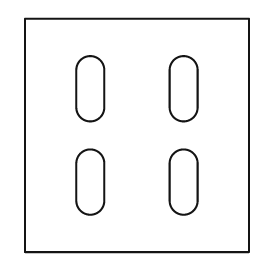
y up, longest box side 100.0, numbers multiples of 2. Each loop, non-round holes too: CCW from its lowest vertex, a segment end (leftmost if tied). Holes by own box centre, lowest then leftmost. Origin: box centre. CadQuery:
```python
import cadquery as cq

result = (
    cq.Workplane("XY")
    .moveTo(-48.0, -50.0)
    .lineTo(48.0, -50.0)
    .lineTo(48.0, 50.0)
    .lineTo(-48.0, 50.0)
    .close()
    .moveTo(-26.0, -28.0)
    .threePointArc((-20.0, -34.0), (-14.0, -28.0))
    .lineTo(-14.0, -12.0)
    .threePointArc((-20.0, -6.0), (-26.0, -12.0))
    .close()
    .moveTo(14.0, -28.0)
    .threePointArc((20.0, -34.0), (26.0, -28.0))
    .lineTo(26.0, -12.0)
    .threePointArc((20.0, -6.0), (14.0, -12.0))
    .close()
    .moveTo(-26.0, 12.0)
    .threePointArc((-20.0, 6.0), (-14.0, 12.0))
    .lineTo(-14.0, 28.0)
    .threePointArc((-20.0, 34.0), (-26.0, 28.0))
    .close()
    .moveTo(14.0, 12.0)
    .threePointArc((20.0, 6.0), (26.0, 12.0))
    .lineTo(26.0, 28.0)
    .threePointArc((20.0, 34.0), (14.0, 28.0))
    .close()
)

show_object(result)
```